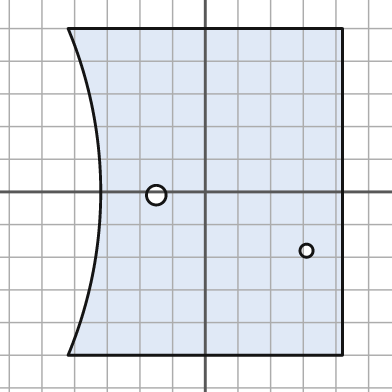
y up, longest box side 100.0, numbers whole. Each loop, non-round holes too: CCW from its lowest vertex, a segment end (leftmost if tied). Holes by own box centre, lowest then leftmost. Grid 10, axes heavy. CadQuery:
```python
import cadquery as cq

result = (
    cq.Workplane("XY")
    .moveTo(-42.0, -50.0)
    .lineTo(42.0, -50.0)
    .lineTo(42.0, 50.0)
    .lineTo(-42.0, 50.0)
    .threePointArc((-32.0, 0.0), (-42.0, -50.0))
    .close()
    .moveTo(31.0, -18.0)
    .circle(2.0)
    .moveTo(-15.0, -1.0)
    .circle(3.0)
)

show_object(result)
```